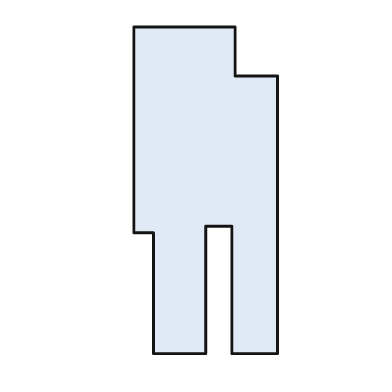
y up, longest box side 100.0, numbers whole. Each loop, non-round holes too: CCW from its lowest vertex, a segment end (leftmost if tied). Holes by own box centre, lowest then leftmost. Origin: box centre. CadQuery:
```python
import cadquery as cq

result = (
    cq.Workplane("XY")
    .moveTo(-16.0, -50.0)
    .lineTo(0.0, -50.0)
    .lineTo(0.0, -11.0)
    .lineTo(8.0, -11.0)
    .lineTo(8.0, -50.0)
    .lineTo(22.0, -50.0)
    .lineTo(22.0, 35.0)
    .lineTo(9.0, 35.0)
    .lineTo(9.0, 50.0)
    .lineTo(-22.0, 50.0)
    .lineTo(-22.0, -13.0)
    .lineTo(-16.0, -13.0)
    .close()
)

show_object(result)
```